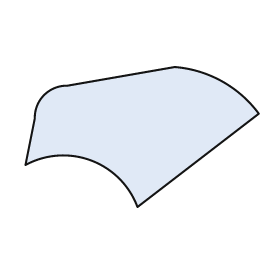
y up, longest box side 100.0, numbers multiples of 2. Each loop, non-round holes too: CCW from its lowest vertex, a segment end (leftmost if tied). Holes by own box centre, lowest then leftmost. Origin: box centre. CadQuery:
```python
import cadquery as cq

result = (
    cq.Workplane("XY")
    .moveTo(-2.0, -30.0)
    .lineTo(50.0, 10.0)
    .threePointArc((34.0, 24.0), (14.0, 30.0))
    .lineTo(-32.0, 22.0)
    .threePointArc((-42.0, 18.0), (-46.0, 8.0))
    .lineTo(-50.0, -12.0)
    .threePointArc((-22.0, -10.0), (-2.0, -30.0))
    .close()
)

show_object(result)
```